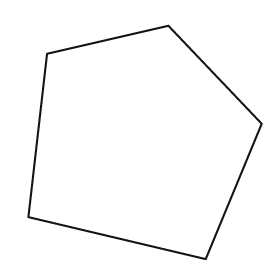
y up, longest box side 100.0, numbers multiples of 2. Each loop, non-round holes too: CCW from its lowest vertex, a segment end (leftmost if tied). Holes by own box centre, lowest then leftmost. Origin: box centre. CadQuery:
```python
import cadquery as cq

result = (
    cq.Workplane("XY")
    .moveTo(26.0, -50.0)
    .lineTo(50.0, 8.0)
    .lineTo(10.0, 50.0)
    .lineTo(-42.0, 38.0)
    .lineTo(-50.0, -32.0)
    .close()
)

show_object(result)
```